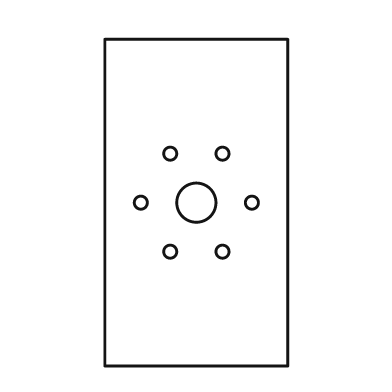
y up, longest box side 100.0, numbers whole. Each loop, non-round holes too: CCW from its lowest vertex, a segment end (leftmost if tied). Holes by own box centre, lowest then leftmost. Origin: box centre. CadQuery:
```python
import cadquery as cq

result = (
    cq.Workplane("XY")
    .moveTo(-28.0, -50.0)
    .lineTo(28.0, -50.0)
    .lineTo(28.0, 50.0)
    .lineTo(-28.0, 50.0)
    .close()
    .moveTo(-8.0, -15.0)
    .circle(2.0)
    .moveTo(8.0, -15.0)
    .circle(2.0)
    .moveTo(-17.0, 0.0)
    .circle(2.0)
    .moveTo(0.0, 0.0)
    .circle(6.0)
    .moveTo(17.0, 0.0)
    .circle(2.0)
    .moveTo(-8.0, 15.0)
    .circle(2.0)
    .moveTo(8.0, 15.0)
    .circle(2.0)
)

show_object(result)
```